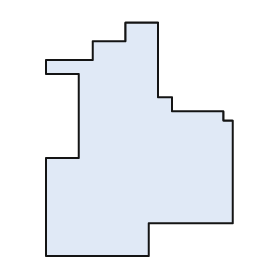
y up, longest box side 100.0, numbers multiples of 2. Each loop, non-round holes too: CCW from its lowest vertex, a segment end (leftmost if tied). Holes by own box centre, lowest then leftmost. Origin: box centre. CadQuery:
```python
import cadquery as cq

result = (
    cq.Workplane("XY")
    .moveTo(-40.0, -50.0)
    .lineTo(4.0, -50.0)
    .lineTo(4.0, -36.0)
    .lineTo(40.0, -36.0)
    .lineTo(40.0, 8.0)
    .lineTo(36.0, 8.0)
    .lineTo(36.0, 12.0)
    .lineTo(14.0, 12.0)
    .lineTo(14.0, 18.0)
    .lineTo(8.0, 18.0)
    .lineTo(8.0, 50.0)
    .lineTo(-6.0, 50.0)
    .lineTo(-6.0, 42.0)
    .lineTo(-20.0, 42.0)
    .lineTo(-20.0, 34.0)
    .lineTo(-40.0, 34.0)
    .lineTo(-40.0, 28.0)
    .lineTo(-26.0, 28.0)
    .lineTo(-26.0, -8.0)
    .lineTo(-40.0, -8.0)
    .close()
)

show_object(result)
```